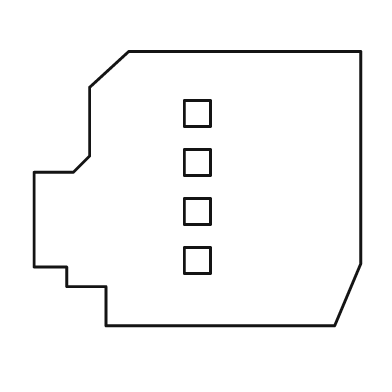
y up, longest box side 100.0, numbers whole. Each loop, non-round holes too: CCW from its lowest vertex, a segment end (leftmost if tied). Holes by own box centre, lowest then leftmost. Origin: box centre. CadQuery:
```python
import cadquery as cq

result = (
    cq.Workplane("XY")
    .moveTo(-28.0, -42.0)
    .lineTo(42.0, -42.0)
    .lineTo(50.0, -23.0)
    .lineTo(50.0, 42.0)
    .lineTo(-21.0, 42.0)
    .lineTo(-33.0, 31.0)
    .lineTo(-33.0, 10.0)
    .lineTo(-38.0, 5.0)
    .lineTo(-50.0, 5.0)
    .lineTo(-50.0, -24.0)
    .lineTo(-40.0, -24.0)
    .lineTo(-40.0, -30.0)
    .lineTo(-28.0, -30.0)
    .close()
    .moveTo(-4.0, -26.0)
    .lineTo(4.0, -26.0)
    .lineTo(4.0, -18.0)
    .lineTo(-4.0, -18.0)
    .close()
    .moveTo(-4.0, -11.0)
    .lineTo(4.0, -11.0)
    .lineTo(4.0, -3.0)
    .lineTo(-4.0, -3.0)
    .close()
    .moveTo(-4.0, 4.0)
    .lineTo(4.0, 4.0)
    .lineTo(4.0, 12.0)
    .lineTo(-4.0, 12.0)
    .close()
    .moveTo(-4.0, 19.0)
    .lineTo(4.0, 19.0)
    .lineTo(4.0, 27.0)
    .lineTo(-4.0, 27.0)
    .close()
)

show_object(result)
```